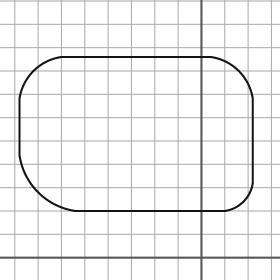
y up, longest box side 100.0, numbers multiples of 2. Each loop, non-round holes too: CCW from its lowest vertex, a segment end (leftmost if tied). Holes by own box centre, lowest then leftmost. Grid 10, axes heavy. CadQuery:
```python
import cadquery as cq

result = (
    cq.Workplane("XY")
    .moveTo(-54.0, 20.0)
    .lineTo(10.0, 20.0)
    .threePointArc((18.0, 24.0), (22.0, 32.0))
    .lineTo(22.0, 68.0)
    .threePointArc((16.0, 80.0), (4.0, 86.0))
    .lineTo(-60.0, 86.0)
    .threePointArc((-72.0, 80.0), (-78.0, 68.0))
    .lineTo(-78.0, 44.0)
    .threePointArc((-70.0, 28.0), (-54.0, 20.0))
    .close()
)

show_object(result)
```